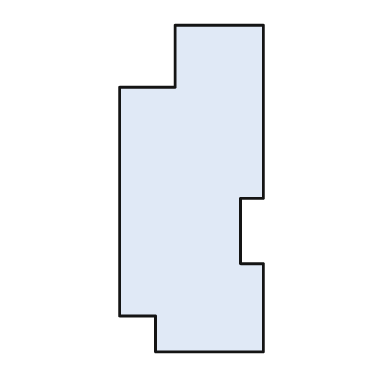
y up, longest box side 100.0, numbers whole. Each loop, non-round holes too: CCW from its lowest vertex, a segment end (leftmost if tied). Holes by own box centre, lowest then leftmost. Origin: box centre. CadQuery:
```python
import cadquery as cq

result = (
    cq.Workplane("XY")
    .moveTo(-11.0, -50.0)
    .lineTo(22.0, -50.0)
    .lineTo(22.0, -23.0)
    .lineTo(15.0, -23.0)
    .lineTo(15.0, -3.0)
    .lineTo(22.0, -3.0)
    .lineTo(22.0, 50.0)
    .lineTo(-5.0, 50.0)
    .lineTo(-5.0, 31.0)
    .lineTo(-22.0, 31.0)
    .lineTo(-22.0, -39.0)
    .lineTo(-11.0, -39.0)
    .close()
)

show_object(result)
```